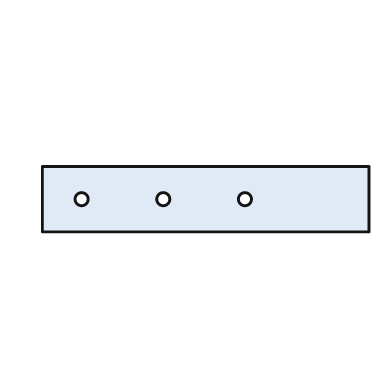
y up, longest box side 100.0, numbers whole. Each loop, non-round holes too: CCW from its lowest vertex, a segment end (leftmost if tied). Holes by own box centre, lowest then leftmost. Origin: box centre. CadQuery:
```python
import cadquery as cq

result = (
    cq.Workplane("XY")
    .moveTo(-50.0, -10.0)
    .lineTo(50.0, -10.0)
    .lineTo(50.0, 10.0)
    .lineTo(-50.0, 10.0)
    .close()
    .moveTo(-38.0, 0.0)
    .circle(2.0)
    .moveTo(-13.0, 0.0)
    .circle(2.0)
    .moveTo(12.0, 0.0)
    .circle(2.0)
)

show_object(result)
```